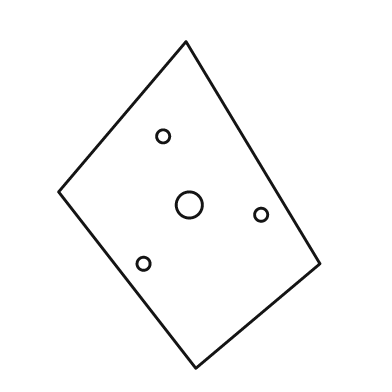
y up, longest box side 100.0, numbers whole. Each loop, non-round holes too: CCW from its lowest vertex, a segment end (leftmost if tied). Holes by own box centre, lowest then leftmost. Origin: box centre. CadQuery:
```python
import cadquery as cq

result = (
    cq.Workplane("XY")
    .moveTo(2.0, -50.0)
    .lineTo(40.0, -18.0)
    .lineTo(-1.0, 50.0)
    .lineTo(-40.0, 4.0)
    .close()
    .moveTo(-14.0, -18.0)
    .circle(2.0)
    .moveTo(22.0, -3.0)
    .circle(2.0)
    .moveTo(0.0, 0.0)
    .circle(4.0)
    .moveTo(-8.0, 21.0)
    .circle(2.0)
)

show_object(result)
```